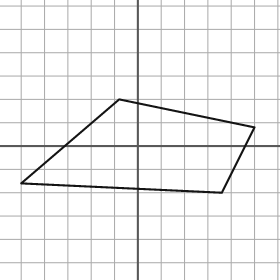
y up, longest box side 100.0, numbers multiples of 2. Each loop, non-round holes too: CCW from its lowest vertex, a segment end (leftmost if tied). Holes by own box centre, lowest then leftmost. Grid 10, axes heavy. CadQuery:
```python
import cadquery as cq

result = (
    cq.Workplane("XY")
    .moveTo(36.0, -20.0)
    .lineTo(50.0, 8.0)
    .lineTo(-8.0, 20.0)
    .lineTo(-50.0, -16.0)
    .close()
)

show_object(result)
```